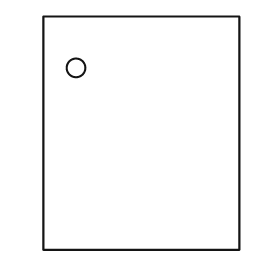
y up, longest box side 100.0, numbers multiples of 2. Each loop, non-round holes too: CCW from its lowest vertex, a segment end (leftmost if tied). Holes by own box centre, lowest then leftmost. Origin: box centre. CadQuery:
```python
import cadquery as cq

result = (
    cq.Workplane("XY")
    .moveTo(-42.0, -50.0)
    .lineTo(42.0, -50.0)
    .lineTo(42.0, 50.0)
    .lineTo(-42.0, 50.0)
    .close()
    .moveTo(-28.0, 28.0)
    .circle(4.0)
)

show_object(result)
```